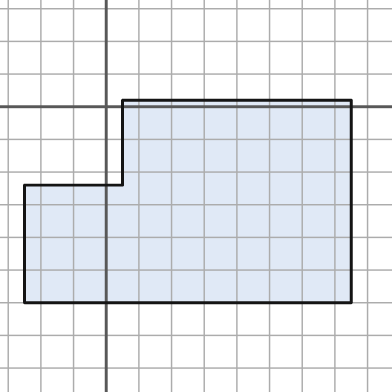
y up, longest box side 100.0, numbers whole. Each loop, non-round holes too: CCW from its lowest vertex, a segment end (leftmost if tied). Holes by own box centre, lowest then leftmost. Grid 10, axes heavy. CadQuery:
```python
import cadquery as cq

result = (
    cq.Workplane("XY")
    .moveTo(-25.0, -60.0)
    .lineTo(75.0, -60.0)
    .lineTo(75.0, 2.0)
    .lineTo(5.0, 2.0)
    .lineTo(5.0, -24.0)
    .lineTo(-25.0, -24.0)
    .close()
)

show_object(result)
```